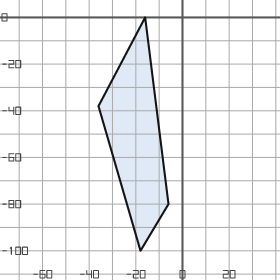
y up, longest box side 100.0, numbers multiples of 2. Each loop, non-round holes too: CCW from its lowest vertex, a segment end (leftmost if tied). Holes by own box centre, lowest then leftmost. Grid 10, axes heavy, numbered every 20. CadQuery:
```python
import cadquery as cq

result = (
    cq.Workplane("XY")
    .moveTo(-18.0, -100.0)
    .lineTo(-6.0, -80.0)
    .lineTo(-16.0, 0.0)
    .lineTo(-36.0, -38.0)
    .close()
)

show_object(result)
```